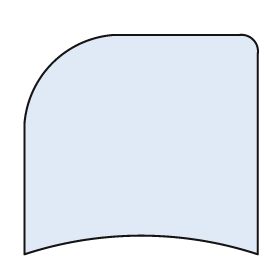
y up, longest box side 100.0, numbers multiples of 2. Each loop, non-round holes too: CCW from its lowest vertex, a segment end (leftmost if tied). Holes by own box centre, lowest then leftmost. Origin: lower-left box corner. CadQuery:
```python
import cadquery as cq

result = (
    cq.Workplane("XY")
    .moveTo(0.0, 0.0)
    .threePointArc((50.0, 8.0), (100.0, 0.0))
    .lineTo(100.0, 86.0)
    .threePointArc((98.0, 92.0), (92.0, 94.0))
    .lineTo(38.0, 94.0)
    .threePointArc((12.0, 82.0), (0.0, 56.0))
    .close()
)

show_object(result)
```